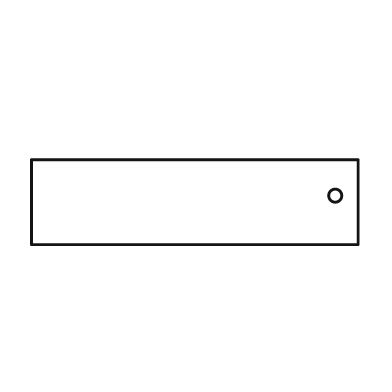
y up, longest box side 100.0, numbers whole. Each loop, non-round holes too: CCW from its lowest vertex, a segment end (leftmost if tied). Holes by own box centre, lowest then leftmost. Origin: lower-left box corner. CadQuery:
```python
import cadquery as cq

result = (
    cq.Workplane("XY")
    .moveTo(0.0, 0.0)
    .lineTo(100.0, 0.0)
    .lineTo(100.0, 26.0)
    .lineTo(0.0, 26.0)
    .close()
    .moveTo(93.0, 15.0)
    .circle(2.0)
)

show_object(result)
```